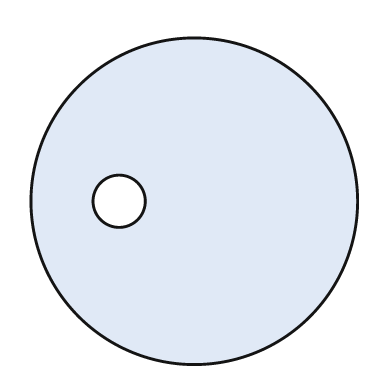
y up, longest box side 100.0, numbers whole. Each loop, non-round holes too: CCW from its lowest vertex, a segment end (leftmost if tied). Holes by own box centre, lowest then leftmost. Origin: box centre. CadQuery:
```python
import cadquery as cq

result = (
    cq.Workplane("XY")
    .moveTo(0.0, 0.0)
    .circle(50.0)
    .moveTo(-23.0, 0.0)
    .circle(8.0)
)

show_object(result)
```